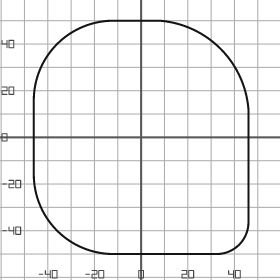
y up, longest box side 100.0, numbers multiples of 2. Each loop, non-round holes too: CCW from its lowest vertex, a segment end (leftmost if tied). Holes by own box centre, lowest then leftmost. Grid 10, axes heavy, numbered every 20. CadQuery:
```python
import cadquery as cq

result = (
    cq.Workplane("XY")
    .moveTo(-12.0, -50.0)
    .lineTo(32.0, -50.0)
    .threePointArc((42.0, -46.0), (46.0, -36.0))
    .lineTo(46.0, 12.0)
    .threePointArc((34.0, 38.0), (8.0, 50.0))
    .lineTo(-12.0, 50.0)
    .threePointArc((-36.0, 40.0), (-46.0, 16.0))
    .lineTo(-46.0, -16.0)
    .threePointArc((-36.0, -40.0), (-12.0, -50.0))
    .close()
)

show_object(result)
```